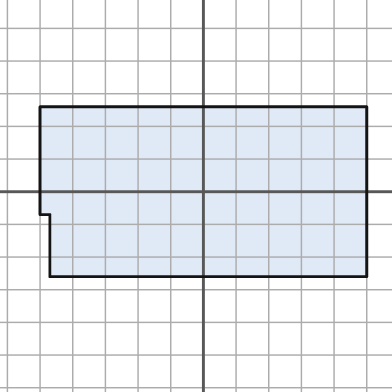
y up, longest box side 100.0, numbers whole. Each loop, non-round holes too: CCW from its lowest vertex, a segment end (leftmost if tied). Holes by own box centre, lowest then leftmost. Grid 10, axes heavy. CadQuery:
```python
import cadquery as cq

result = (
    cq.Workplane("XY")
    .moveTo(-47.0, -26.0)
    .lineTo(50.0, -26.0)
    .lineTo(50.0, 26.0)
    .lineTo(-50.0, 26.0)
    .lineTo(-50.0, -7.0)
    .lineTo(-47.0, -7.0)
    .close()
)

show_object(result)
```